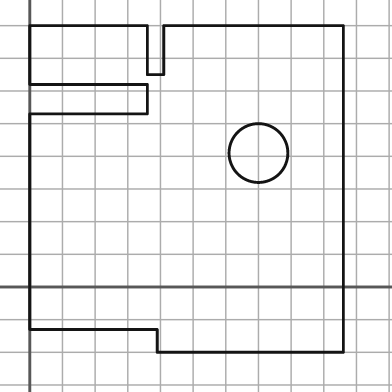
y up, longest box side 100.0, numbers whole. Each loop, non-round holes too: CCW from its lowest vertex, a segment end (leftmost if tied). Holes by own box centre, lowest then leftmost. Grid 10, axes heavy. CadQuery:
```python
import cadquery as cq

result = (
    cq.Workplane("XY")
    .moveTo(39.0, -20.0)
    .lineTo(96.0, -20.0)
    .lineTo(96.0, 80.0)
    .lineTo(41.0, 80.0)
    .lineTo(41.0, 65.0)
    .lineTo(36.0, 65.0)
    .lineTo(36.0, 80.0)
    .lineTo(0.0, 80.0)
    .lineTo(0.0, 62.0)
    .lineTo(36.0, 62.0)
    .lineTo(36.0, 53.0)
    .lineTo(0.0, 53.0)
    .lineTo(0.0, -13.0)
    .lineTo(39.0, -13.0)
    .close()
    .moveTo(70.0, 41.0)
    .circle(9.0)
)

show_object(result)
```